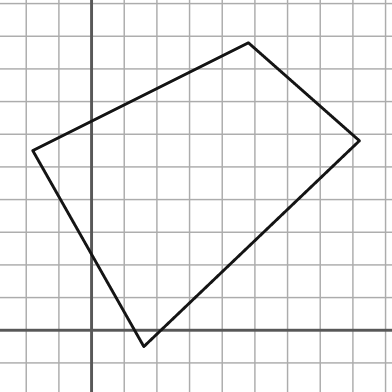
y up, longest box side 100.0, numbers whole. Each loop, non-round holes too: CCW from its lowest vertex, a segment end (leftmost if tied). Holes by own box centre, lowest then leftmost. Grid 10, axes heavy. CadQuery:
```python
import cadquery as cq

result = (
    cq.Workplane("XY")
    .moveTo(16.0, -5.0)
    .lineTo(82.0, 58.0)
    .lineTo(48.0, 88.0)
    .lineTo(-18.0, 55.0)
    .close()
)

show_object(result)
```